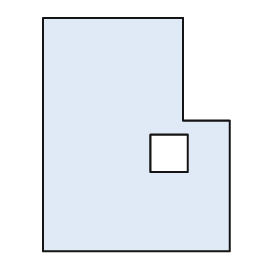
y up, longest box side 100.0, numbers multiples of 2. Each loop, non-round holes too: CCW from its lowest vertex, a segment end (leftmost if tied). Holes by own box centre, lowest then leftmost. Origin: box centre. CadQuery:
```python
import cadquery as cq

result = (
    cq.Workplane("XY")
    .moveTo(-40.0, -50.0)
    .lineTo(40.0, -50.0)
    .lineTo(40.0, 6.0)
    .lineTo(20.0, 6.0)
    .lineTo(20.0, 50.0)
    .lineTo(-40.0, 50.0)
    .close()
    .moveTo(6.0, -16.0)
    .lineTo(22.0, -16.0)
    .lineTo(22.0, 0.0)
    .lineTo(6.0, 0.0)
    .close()
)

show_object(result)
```